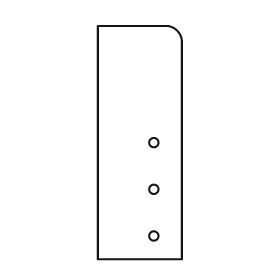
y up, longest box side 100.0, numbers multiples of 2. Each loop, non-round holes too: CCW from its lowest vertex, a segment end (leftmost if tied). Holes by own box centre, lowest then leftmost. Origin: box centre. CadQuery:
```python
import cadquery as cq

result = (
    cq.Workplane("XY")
    .moveTo(-18.0, -50.0)
    .lineTo(18.0, -50.0)
    .lineTo(18.0, 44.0)
    .threePointArc((16.0, 48.0), (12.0, 50.0))
    .lineTo(-18.0, 50.0)
    .close()
    .moveTo(6.0, -40.0)
    .circle(2.0)
    .moveTo(6.0, -20.0)
    .circle(2.0)
    .moveTo(6.0, 0.0)
    .circle(2.0)
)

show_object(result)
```